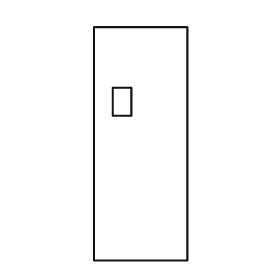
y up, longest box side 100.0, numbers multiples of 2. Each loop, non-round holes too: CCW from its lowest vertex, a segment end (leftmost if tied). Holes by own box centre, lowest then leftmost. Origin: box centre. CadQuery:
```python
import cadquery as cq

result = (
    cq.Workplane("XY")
    .moveTo(-20.0, -50.0)
    .lineTo(20.0, -50.0)
    .lineTo(20.0, 50.0)
    .lineTo(-20.0, 50.0)
    .close()
    .moveTo(-12.0, 12.0)
    .lineTo(-4.0, 12.0)
    .lineTo(-4.0, 24.0)
    .lineTo(-12.0, 24.0)
    .close()
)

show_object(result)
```